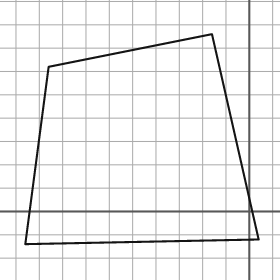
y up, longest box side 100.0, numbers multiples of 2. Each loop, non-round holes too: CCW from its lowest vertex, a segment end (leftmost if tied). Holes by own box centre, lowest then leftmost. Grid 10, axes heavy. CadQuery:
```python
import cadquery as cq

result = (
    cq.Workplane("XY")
    .moveTo(-96.0, -14.0)
    .lineTo(4.0, -12.0)
    .lineTo(-16.0, 76.0)
    .lineTo(-86.0, 62.0)
    .close()
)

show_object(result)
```